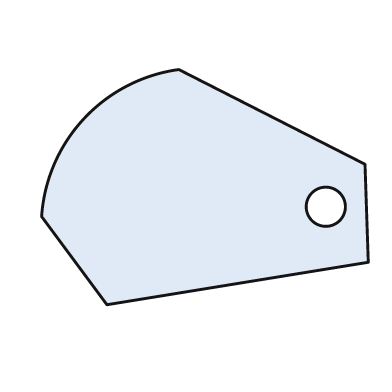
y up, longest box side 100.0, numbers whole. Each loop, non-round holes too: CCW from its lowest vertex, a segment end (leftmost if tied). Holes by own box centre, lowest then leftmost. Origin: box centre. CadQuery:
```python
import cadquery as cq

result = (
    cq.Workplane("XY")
    .moveTo(-30.0, -36.0)
    .lineTo(50.0, -23.0)
    .lineTo(49.0, 7.0)
    .lineTo(-8.0, 36.0)
    .threePointArc((-37.0, 21.0), (-50.0, -9.0))
    .close()
    .moveTo(37.0, -6.0)
    .circle(6.0)
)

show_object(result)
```